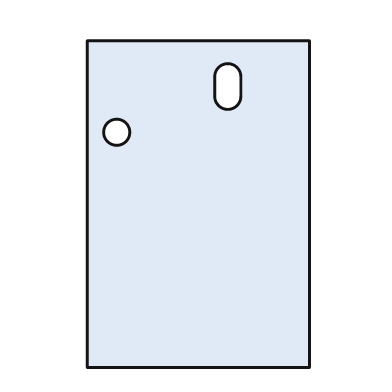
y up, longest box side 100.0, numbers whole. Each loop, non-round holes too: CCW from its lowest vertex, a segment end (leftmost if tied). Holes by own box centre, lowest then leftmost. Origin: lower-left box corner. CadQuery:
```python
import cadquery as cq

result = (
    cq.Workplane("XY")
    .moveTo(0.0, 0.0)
    .lineTo(68.0, 0.0)
    .lineTo(68.0, 100.0)
    .lineTo(0.0, 100.0)
    .close()
    .moveTo(9.0, 72.0)
    .circle(4.0)
    .moveTo(39.0, 83.0)
    .threePointArc((43.0, 79.0), (47.0, 83.0))
    .lineTo(47.0, 89.0)
    .threePointArc((43.0, 93.0), (39.0, 89.0))
    .close()
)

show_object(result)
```